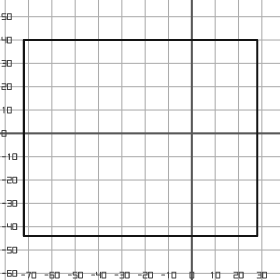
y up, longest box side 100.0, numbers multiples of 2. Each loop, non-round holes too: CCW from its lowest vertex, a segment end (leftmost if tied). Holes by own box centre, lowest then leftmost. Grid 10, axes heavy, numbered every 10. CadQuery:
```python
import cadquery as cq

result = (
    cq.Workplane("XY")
    .moveTo(-72.0, -44.0)
    .lineTo(28.0, -44.0)
    .lineTo(28.0, 40.0)
    .lineTo(-72.0, 40.0)
    .close()
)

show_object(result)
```